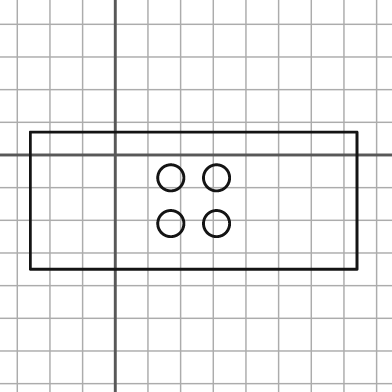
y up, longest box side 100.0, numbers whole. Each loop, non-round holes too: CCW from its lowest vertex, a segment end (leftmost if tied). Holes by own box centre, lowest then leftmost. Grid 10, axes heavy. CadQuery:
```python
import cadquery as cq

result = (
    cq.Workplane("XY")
    .moveTo(-26.0, -35.0)
    .lineTo(74.0, -35.0)
    .lineTo(74.0, 7.0)
    .lineTo(-26.0, 7.0)
    .close()
    .moveTo(17.0, -21.0)
    .circle(4.0)
    .moveTo(31.0, -21.0)
    .circle(4.0)
    .moveTo(17.0, -7.0)
    .circle(4.0)
    .moveTo(31.0, -7.0)
    .circle(4.0)
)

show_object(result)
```